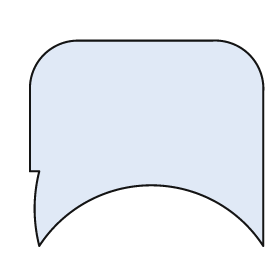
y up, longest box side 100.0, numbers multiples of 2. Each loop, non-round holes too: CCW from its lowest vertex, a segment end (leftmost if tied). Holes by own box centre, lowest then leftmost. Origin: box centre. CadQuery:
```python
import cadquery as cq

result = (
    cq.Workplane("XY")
    .moveTo(-46.0, -44.0)
    .threePointArc((2.0, -18.0), (50.0, -44.0))
    .lineTo(50.0, 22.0)
    .threePointArc((44.0, 38.0), (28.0, 44.0))
    .lineTo(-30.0, 44.0)
    .threePointArc((-44.0, 38.0), (-50.0, 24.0))
    .lineTo(-50.0, -12.0)
    .lineTo(-46.0, -12.0)
    .threePointArc((-48.0, -28.0), (-46.0, -44.0))
    .close()
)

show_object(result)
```